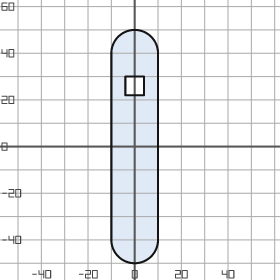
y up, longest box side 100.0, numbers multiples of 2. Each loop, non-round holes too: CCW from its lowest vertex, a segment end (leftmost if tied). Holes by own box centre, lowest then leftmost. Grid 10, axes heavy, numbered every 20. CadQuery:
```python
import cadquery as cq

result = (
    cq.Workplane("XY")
    .moveTo(-10.0, -40.0)
    .threePointArc((0.0, -50.0), (10.0, -40.0))
    .lineTo(10.0, 40.0)
    .threePointArc((0.0, 50.0), (-10.0, 40.0))
    .close()
    .moveTo(-4.0, 22.0)
    .lineTo(4.0, 22.0)
    .lineTo(4.0, 30.0)
    .lineTo(-4.0, 30.0)
    .close()
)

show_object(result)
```